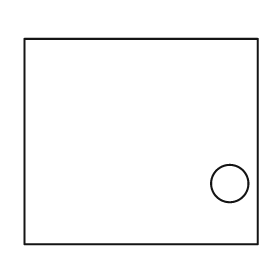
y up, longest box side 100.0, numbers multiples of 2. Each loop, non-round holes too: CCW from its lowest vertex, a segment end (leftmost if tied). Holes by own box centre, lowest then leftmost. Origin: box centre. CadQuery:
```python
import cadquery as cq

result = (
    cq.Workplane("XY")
    .moveTo(-50.0, -44.0)
    .lineTo(50.0, -44.0)
    .lineTo(50.0, 44.0)
    .lineTo(-50.0, 44.0)
    .close()
    .moveTo(38.0, -18.0)
    .circle(8.0)
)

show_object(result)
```